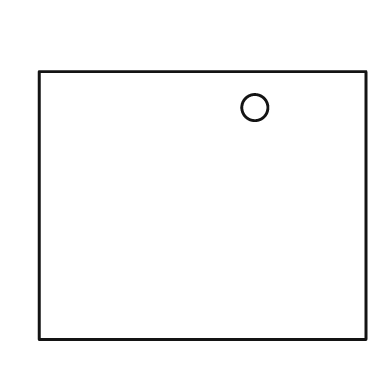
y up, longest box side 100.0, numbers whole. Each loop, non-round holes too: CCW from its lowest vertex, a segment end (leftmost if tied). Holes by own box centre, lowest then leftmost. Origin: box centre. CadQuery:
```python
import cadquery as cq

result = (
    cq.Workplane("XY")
    .moveTo(-50.0, -41.0)
    .lineTo(50.0, -41.0)
    .lineTo(50.0, 41.0)
    .lineTo(-50.0, 41.0)
    .close()
    .moveTo(16.0, 30.0)
    .circle(4.0)
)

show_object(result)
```